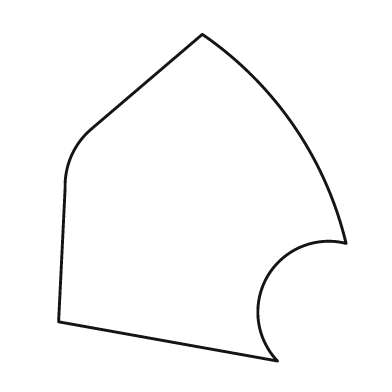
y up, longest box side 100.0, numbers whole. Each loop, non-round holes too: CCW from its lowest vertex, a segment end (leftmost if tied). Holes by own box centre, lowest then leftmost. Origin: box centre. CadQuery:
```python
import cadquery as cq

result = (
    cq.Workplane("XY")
    .moveTo(23.0, -50.0)
    .threePointArc((20.0, -24.0), (44.0, -14.0))
    .threePointArc((28.0, 22.0), (0.0, 50.0))
    .lineTo(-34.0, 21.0)
    .threePointArc((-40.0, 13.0), (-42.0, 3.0))
    .lineTo(-44.0, -38.0)
    .close()
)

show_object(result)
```